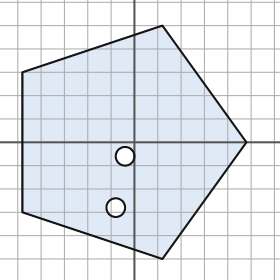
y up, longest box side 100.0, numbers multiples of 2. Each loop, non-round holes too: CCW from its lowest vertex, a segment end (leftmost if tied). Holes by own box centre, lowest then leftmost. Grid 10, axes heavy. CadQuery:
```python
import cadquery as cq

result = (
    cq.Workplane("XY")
    .moveTo(12.0, -50.0)
    .lineTo(48.0, 0.0)
    .lineTo(12.0, 50.0)
    .lineTo(-48.0, 30.0)
    .lineTo(-48.0, -30.0)
    .close()
    .moveTo(-8.0, -28.0)
    .circle(4.0)
    .moveTo(-4.0, -6.0)
    .circle(4.0)
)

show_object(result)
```